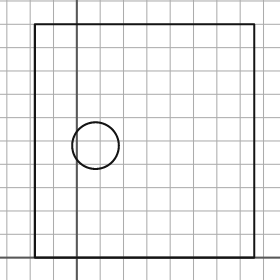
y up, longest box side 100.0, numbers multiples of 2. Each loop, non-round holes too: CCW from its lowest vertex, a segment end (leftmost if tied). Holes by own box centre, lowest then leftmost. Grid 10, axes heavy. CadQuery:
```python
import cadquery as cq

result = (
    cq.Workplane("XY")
    .moveTo(-18.0, 0.0)
    .lineTo(76.0, 0.0)
    .lineTo(76.0, 100.0)
    .lineTo(-18.0, 100.0)
    .close()
    .moveTo(8.0, 48.0)
    .circle(10.0)
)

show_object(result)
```